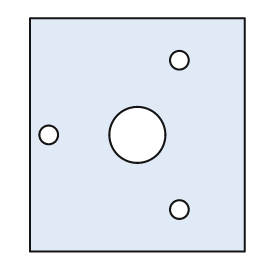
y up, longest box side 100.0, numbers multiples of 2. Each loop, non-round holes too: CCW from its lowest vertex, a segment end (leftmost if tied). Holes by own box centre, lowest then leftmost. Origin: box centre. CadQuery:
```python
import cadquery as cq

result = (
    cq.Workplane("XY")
    .moveTo(-46.0, -50.0)
    .lineTo(46.0, -50.0)
    .lineTo(46.0, 50.0)
    .lineTo(-46.0, 50.0)
    .close()
    .moveTo(18.0, -32.0)
    .circle(4.0)
    .moveTo(-38.0, 0.0)
    .circle(4.0)
    .moveTo(0.0, 0.0)
    .circle(12.0)
    .moveTo(18.0, 32.0)
    .circle(4.0)
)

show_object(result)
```